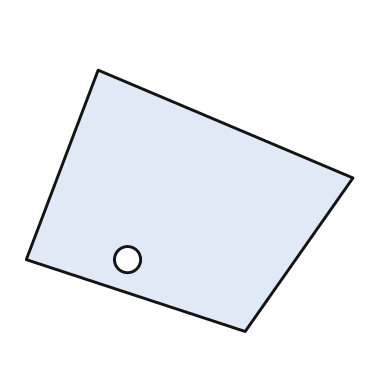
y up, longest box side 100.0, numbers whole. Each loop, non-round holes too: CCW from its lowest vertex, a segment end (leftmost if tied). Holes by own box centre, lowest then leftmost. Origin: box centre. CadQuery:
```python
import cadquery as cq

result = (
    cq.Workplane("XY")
    .moveTo(17.0, -40.0)
    .lineTo(50.0, 7.0)
    .lineTo(-28.0, 40.0)
    .lineTo(-50.0, -18.0)
    .close()
    .moveTo(-19.0, -18.0)
    .circle(4.0)
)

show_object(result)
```